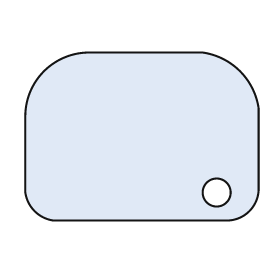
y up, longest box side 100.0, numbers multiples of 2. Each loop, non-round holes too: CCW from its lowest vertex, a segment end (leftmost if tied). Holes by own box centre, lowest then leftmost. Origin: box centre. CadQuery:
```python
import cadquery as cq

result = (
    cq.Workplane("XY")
    .moveTo(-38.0, -36.0)
    .lineTo(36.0, -36.0)
    .threePointArc((46.0, -32.0), (50.0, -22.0))
    .lineTo(50.0, 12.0)
    .threePointArc((42.0, 28.0), (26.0, 36.0))
    .lineTo(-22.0, 36.0)
    .threePointArc((-42.0, 28.0), (-50.0, 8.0))
    .lineTo(-50.0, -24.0)
    .threePointArc((-46.0, -32.0), (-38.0, -36.0))
    .close()
    .moveTo(32.0, -24.0)
    .circle(6.0)
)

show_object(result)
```